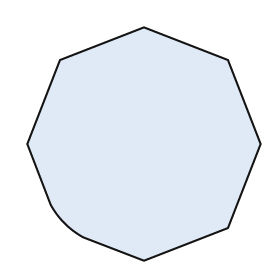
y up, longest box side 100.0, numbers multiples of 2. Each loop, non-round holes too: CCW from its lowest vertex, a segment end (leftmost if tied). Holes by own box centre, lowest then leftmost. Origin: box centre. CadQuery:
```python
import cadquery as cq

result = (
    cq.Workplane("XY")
    .moveTo(0.0, -50.0)
    .lineTo(36.0, -36.0)
    .lineTo(50.0, 0.0)
    .lineTo(36.0, 36.0)
    .lineTo(0.0, 50.0)
    .lineTo(-36.0, 36.0)
    .lineTo(-50.0, 0.0)
    .lineTo(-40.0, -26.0)
    .threePointArc((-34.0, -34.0), (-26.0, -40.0))
    .close()
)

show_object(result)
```